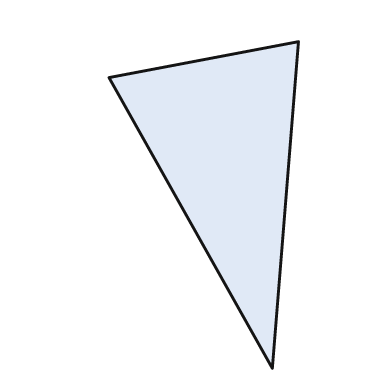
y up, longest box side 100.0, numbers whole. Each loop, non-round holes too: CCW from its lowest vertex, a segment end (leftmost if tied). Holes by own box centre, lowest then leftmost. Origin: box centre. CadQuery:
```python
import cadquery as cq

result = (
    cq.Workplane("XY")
    .moveTo(21.0, -50.0)
    .lineTo(29.0, 50.0)
    .lineTo(-29.0, 39.0)
    .close()
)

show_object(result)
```